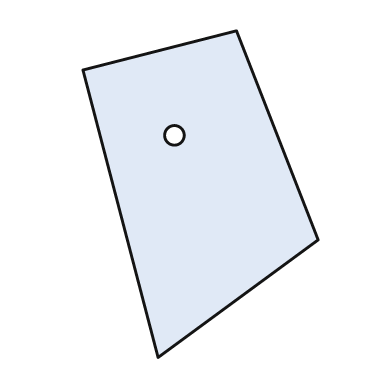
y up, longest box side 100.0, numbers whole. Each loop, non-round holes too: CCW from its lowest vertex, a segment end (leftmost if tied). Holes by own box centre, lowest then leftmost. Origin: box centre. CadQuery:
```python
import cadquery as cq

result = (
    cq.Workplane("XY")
    .moveTo(-13.0, -50.0)
    .lineTo(36.0, -14.0)
    .lineTo(11.0, 50.0)
    .lineTo(-36.0, 38.0)
    .close()
    .moveTo(-8.0, 18.0)
    .circle(3.0)
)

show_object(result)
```